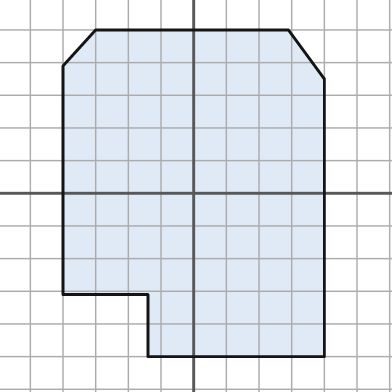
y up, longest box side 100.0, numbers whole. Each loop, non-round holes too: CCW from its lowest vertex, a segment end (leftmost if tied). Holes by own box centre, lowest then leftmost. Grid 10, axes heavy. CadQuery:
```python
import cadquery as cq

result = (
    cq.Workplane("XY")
    .moveTo(-14.0, -50.0)
    .lineTo(40.0, -50.0)
    .lineTo(40.0, 35.0)
    .lineTo(29.0, 50.0)
    .lineTo(-30.0, 50.0)
    .lineTo(-40.0, 39.0)
    .lineTo(-40.0, -31.0)
    .lineTo(-14.0, -31.0)
    .close()
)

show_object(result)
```